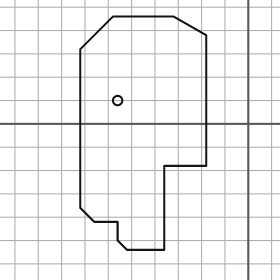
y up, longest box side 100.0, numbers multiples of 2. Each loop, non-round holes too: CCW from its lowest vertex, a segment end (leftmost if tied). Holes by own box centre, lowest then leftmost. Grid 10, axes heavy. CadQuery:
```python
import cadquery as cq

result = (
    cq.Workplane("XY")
    .moveTo(-52.0, -54.0)
    .lineTo(-36.0, -54.0)
    .lineTo(-36.0, -18.0)
    .lineTo(-18.0, -18.0)
    .lineTo(-18.0, 38.0)
    .lineTo(-32.0, 46.0)
    .lineTo(-58.0, 46.0)
    .lineTo(-72.0, 32.0)
    .lineTo(-72.0, -36.0)
    .lineTo(-66.0, -42.0)
    .lineTo(-56.0, -42.0)
    .lineTo(-56.0, -50.0)
    .close()
    .moveTo(-56.0, 10.0)
    .circle(2.0)
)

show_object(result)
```